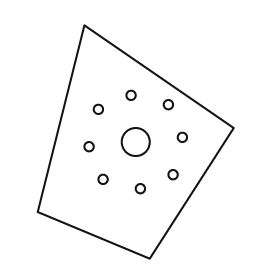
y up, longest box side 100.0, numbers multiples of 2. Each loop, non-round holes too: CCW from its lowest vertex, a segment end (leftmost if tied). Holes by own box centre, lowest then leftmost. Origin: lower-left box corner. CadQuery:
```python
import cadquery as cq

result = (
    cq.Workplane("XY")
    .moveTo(48.0, 0.0)
    .lineTo(84.0, 56.0)
    .lineTo(20.0, 100.0)
    .lineTo(0.0, 20.0)
    .close()
    .moveTo(44.0, 30.0)
    .circle(2.0)
    .moveTo(28.0, 34.0)
    .circle(2.0)
    .moveTo(58.0, 36.0)
    .circle(2.0)
    .moveTo(22.0, 48.0)
    .circle(2.0)
    .moveTo(42.0, 50.0)
    .circle(6.0)
    .moveTo(62.0, 52.0)
    .circle(2.0)
    .moveTo(26.0, 64.0)
    .circle(2.0)
    .moveTo(56.0, 66.0)
    .circle(2.0)
    .moveTo(40.0, 70.0)
    .circle(2.0)
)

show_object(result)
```